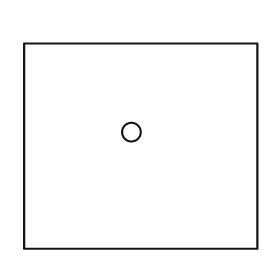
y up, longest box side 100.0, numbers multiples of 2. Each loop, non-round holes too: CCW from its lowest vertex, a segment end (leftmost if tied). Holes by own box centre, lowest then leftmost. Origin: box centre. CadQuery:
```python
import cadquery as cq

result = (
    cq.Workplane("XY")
    .moveTo(-50.0, -44.0)
    .lineTo(50.0, -44.0)
    .lineTo(50.0, 44.0)
    .lineTo(-50.0, 44.0)
    .close()
    .moveTo(-4.0, 6.0)
    .circle(4.0)
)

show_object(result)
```